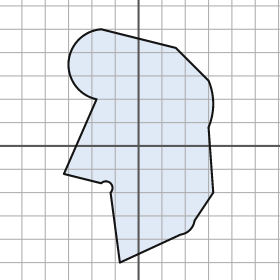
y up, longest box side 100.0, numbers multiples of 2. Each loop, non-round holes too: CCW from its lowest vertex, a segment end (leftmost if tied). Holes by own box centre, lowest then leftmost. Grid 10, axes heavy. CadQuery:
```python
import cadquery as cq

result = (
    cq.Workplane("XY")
    .moveTo(-8.0, -50.0)
    .lineTo(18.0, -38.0)
    .threePointArc((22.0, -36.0), (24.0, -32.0))
    .lineTo(32.0, -20.0)
    .lineTo(30.0, 8.0)
    .threePointArc((32.0, 18.0), (30.0, 28.0))
    .lineTo(16.0, 42.0)
    .lineTo(-16.0, 50.0)
    .threePointArc((-30.0, 36.0), (-18.0, 20.0))
    .lineTo(-32.0, -12.0)
    .lineTo(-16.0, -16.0)
    .threePointArc((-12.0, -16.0), (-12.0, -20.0))
    .close()
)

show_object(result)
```